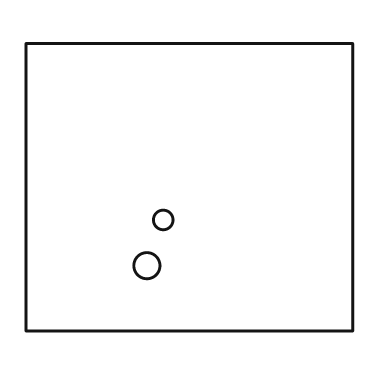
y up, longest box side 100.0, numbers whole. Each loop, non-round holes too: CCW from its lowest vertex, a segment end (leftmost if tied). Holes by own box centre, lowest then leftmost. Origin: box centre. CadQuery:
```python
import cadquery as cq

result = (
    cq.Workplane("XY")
    .moveTo(-50.0, -44.0)
    .lineTo(50.0, -44.0)
    .lineTo(50.0, 44.0)
    .lineTo(-50.0, 44.0)
    .close()
    .moveTo(-13.0, -24.0)
    .circle(4.0)
    .moveTo(-8.0, -10.0)
    .circle(3.0)
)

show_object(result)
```